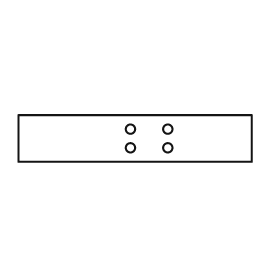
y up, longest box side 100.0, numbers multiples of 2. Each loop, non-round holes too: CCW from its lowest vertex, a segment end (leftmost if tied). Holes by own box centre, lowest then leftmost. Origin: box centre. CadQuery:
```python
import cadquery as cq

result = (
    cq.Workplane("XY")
    .moveTo(-50.0, -10.0)
    .lineTo(50.0, -10.0)
    .lineTo(50.0, 10.0)
    .lineTo(-50.0, 10.0)
    .close()
    .moveTo(-2.0, -4.0)
    .circle(2.0)
    .moveTo(14.0, -4.0)
    .circle(2.0)
    .moveTo(-2.0, 4.0)
    .circle(2.0)
    .moveTo(14.0, 4.0)
    .circle(2.0)
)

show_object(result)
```